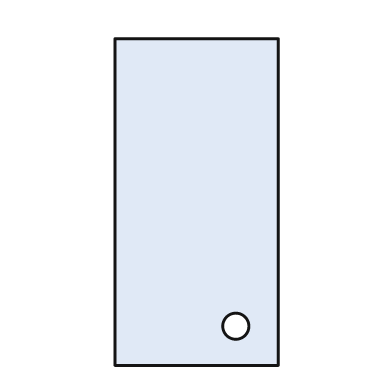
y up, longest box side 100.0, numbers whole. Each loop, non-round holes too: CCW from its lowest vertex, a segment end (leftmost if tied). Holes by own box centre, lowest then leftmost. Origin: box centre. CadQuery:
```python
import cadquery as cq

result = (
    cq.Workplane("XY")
    .moveTo(-25.0, -50.0)
    .lineTo(25.0, -50.0)
    .lineTo(25.0, 50.0)
    .lineTo(-25.0, 50.0)
    .close()
    .moveTo(12.0, -38.0)
    .circle(4.0)
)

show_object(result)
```